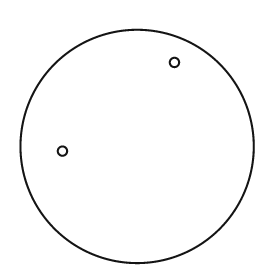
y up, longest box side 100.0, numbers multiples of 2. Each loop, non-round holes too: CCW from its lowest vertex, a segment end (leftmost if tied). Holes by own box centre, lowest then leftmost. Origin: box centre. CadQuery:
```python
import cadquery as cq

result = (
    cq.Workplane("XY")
    .moveTo(0.0, 0.0)
    .circle(50.0)
    .moveTo(-32.0, -2.0)
    .circle(2.0)
    .moveTo(16.0, 36.0)
    .circle(2.0)
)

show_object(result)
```